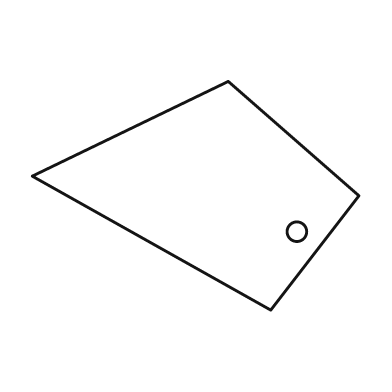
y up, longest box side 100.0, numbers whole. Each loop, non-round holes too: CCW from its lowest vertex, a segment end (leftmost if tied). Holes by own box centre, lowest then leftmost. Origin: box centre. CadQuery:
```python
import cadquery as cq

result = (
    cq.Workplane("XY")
    .moveTo(23.0, -35.0)
    .lineTo(50.0, 0.0)
    .lineTo(10.0, 35.0)
    .lineTo(-50.0, 6.0)
    .close()
    .moveTo(31.0, -11.0)
    .circle(3.0)
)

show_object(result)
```